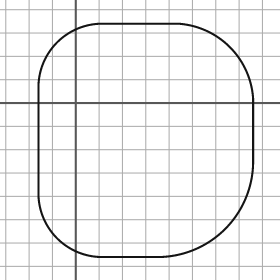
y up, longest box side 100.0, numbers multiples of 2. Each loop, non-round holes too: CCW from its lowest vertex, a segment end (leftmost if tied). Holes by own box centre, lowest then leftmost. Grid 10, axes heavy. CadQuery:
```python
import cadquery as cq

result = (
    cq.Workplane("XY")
    .moveTo(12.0, -66.0)
    .lineTo(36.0, -66.0)
    .threePointArc((64.0, -54.0), (76.0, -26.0))
    .lineTo(76.0, 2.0)
    .threePointArc((66.0, 24.0), (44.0, 34.0))
    .lineTo(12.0, 34.0)
    .threePointArc((-8.0, 26.0), (-16.0, 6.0))
    .lineTo(-16.0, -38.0)
    .threePointArc((-8.0, -58.0), (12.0, -66.0))
    .close()
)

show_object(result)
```